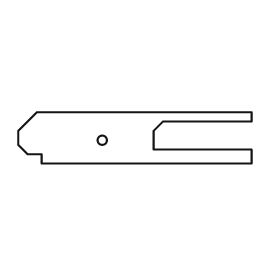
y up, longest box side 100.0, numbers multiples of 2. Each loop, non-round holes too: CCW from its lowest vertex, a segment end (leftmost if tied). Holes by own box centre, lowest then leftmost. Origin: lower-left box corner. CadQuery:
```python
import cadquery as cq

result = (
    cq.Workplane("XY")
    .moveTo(10.0, 0.0)
    .lineTo(100.0, 0.0)
    .lineTo(100.0, 6.0)
    .lineTo(58.0, 6.0)
    .lineTo(58.0, 14.0)
    .lineTo(62.0, 18.0)
    .lineTo(100.0, 18.0)
    .lineTo(100.0, 22.0)
    .lineTo(8.0, 22.0)
    .lineTo(0.0, 14.0)
    .lineTo(0.0, 8.0)
    .lineTo(4.0, 4.0)
    .lineTo(10.0, 4.0)
    .close()
    .moveTo(36.0, 10.0)
    .circle(2.0)
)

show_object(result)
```